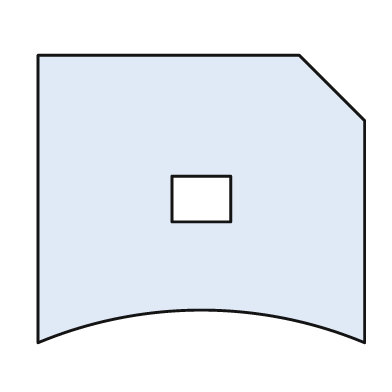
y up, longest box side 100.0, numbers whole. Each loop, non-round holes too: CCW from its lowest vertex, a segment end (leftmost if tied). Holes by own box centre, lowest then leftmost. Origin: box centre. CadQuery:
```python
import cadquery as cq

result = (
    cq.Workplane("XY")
    .moveTo(-50.0, -44.0)
    .threePointArc((0.0, -34.0), (50.0, -44.0))
    .lineTo(50.0, 24.0)
    .lineTo(30.0, 44.0)
    .lineTo(-50.0, 44.0)
    .close()
    .moveTo(-9.0, -7.0)
    .lineTo(9.0, -7.0)
    .lineTo(9.0, 7.0)
    .lineTo(-9.0, 7.0)
    .close()
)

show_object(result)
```